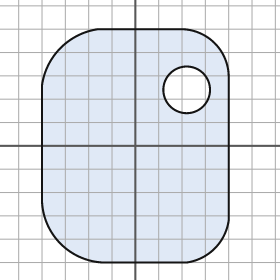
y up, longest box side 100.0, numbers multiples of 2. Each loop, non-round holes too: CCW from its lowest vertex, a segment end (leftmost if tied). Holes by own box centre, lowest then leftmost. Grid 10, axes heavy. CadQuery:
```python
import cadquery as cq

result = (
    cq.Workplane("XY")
    .moveTo(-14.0, -50.0)
    .lineTo(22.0, -50.0)
    .threePointArc((34.0, -44.0), (40.0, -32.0))
    .lineTo(40.0, 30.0)
    .threePointArc((34.0, 44.0), (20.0, 50.0))
    .lineTo(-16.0, 50.0)
    .threePointArc((-32.0, 42.0), (-40.0, 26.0))
    .lineTo(-40.0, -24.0)
    .threePointArc((-32.0, -42.0), (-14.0, -50.0))
    .close()
    .moveTo(22.0, 24.0)
    .circle(10.0)
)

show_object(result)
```